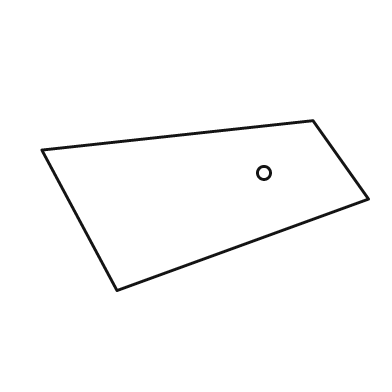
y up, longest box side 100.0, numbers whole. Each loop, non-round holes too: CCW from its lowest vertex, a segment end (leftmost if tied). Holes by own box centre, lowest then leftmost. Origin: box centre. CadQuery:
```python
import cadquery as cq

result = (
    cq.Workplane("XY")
    .moveTo(-27.0, -26.0)
    .lineTo(50.0, 2.0)
    .lineTo(33.0, 26.0)
    .lineTo(-50.0, 17.0)
    .close()
    .moveTo(18.0, 10.0)
    .circle(2.0)
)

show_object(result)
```